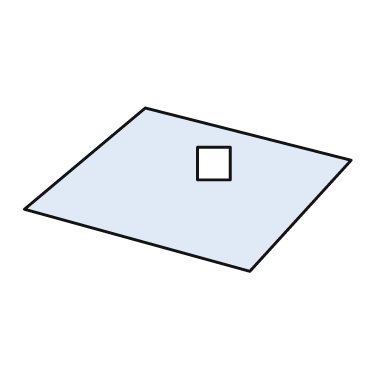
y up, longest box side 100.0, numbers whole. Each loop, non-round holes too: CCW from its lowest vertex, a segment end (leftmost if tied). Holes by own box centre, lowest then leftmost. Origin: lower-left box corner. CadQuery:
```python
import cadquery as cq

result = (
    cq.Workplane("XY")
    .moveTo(69.0, 0.0)
    .lineTo(100.0, 34.0)
    .lineTo(37.0, 50.0)
    .lineTo(0.0, 19.0)
    .close()
    .moveTo(53.0, 28.0)
    .lineTo(63.0, 28.0)
    .lineTo(63.0, 38.0)
    .lineTo(53.0, 38.0)
    .close()
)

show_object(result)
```